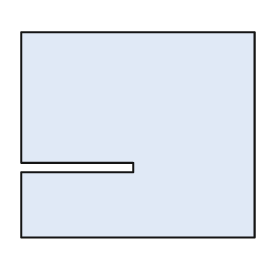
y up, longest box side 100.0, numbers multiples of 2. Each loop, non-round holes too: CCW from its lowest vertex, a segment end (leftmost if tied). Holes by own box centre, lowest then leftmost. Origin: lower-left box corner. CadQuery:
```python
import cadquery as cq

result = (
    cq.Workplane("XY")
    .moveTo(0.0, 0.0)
    .lineTo(100.0, 0.0)
    .lineTo(100.0, 88.0)
    .lineTo(0.0, 88.0)
    .lineTo(0.0, 32.0)
    .lineTo(48.0, 32.0)
    .lineTo(48.0, 28.0)
    .lineTo(0.0, 28.0)
    .close()
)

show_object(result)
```